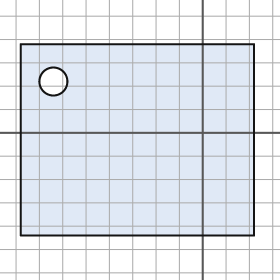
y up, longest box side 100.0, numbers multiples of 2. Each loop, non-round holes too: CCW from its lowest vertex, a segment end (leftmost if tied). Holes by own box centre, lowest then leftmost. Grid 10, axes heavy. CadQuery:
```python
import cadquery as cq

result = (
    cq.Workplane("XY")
    .moveTo(-78.0, -44.0)
    .lineTo(22.0, -44.0)
    .lineTo(22.0, 38.0)
    .lineTo(-78.0, 38.0)
    .close()
    .moveTo(-64.0, 22.0)
    .circle(6.0)
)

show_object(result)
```